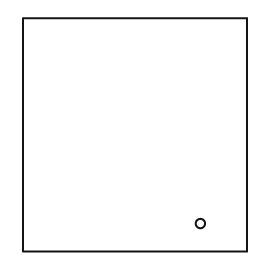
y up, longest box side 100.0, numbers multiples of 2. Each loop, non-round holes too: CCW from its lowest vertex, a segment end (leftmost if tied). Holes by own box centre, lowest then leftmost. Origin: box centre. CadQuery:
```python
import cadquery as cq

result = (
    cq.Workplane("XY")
    .moveTo(-48.0, -50.0)
    .lineTo(48.0, -50.0)
    .lineTo(48.0, 50.0)
    .lineTo(-48.0, 50.0)
    .close()
    .moveTo(28.0, -38.0)
    .circle(2.0)
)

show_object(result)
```